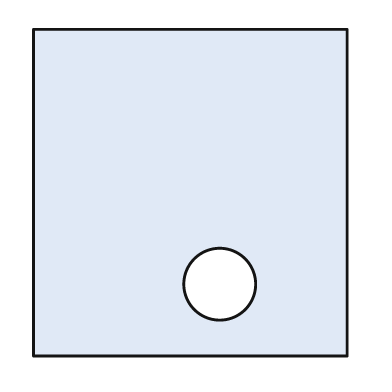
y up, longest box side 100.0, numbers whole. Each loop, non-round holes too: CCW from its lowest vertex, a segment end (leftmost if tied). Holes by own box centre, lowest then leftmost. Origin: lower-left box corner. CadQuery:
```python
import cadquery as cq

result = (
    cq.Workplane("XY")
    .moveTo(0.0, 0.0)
    .lineTo(96.0, 0.0)
    .lineTo(96.0, 100.0)
    .lineTo(0.0, 100.0)
    .close()
    .moveTo(57.0, 22.0)
    .circle(11.0)
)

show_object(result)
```